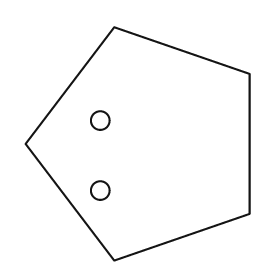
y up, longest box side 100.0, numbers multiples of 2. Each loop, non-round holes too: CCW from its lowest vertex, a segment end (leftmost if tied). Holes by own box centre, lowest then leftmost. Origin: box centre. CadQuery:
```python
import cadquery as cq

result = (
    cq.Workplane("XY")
    .moveTo(-10.0, -50.0)
    .lineTo(48.0, -30.0)
    .lineTo(48.0, 30.0)
    .lineTo(-10.0, 50.0)
    .lineTo(-48.0, 0.0)
    .close()
    .moveTo(-16.0, -20.0)
    .circle(4.0)
    .moveTo(-16.0, 10.0)
    .circle(4.0)
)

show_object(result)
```